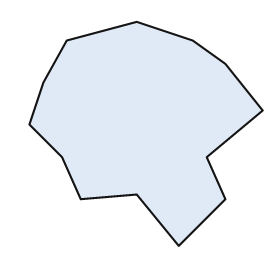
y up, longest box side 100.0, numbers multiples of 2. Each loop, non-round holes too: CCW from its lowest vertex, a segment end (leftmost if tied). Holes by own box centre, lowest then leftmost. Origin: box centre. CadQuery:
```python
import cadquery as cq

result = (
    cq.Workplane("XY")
    .moveTo(14.0, -48.0)
    .lineTo(34.0, -28.0)
    .lineTo(26.0, -10.0)
    .lineTo(50.0, 10.0)
    .lineTo(34.0, 30.0)
    .lineTo(20.0, 40.0)
    .lineTo(-4.0, 48.0)
    .lineTo(-34.0, 40.0)
    .lineTo(-44.0, 22.0)
    .lineTo(-50.0, 4.0)
    .lineTo(-36.0, -10.0)
    .lineTo(-28.0, -28.0)
    .lineTo(-4.0, -26.0)
    .close()
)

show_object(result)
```